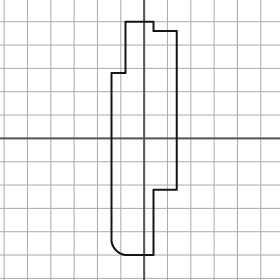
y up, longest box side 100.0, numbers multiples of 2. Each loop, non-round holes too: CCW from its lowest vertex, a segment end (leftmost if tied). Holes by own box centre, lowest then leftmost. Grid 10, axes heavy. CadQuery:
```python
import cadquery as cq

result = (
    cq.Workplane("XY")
    .moveTo(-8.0, -50.0)
    .lineTo(4.0, -50.0)
    .lineTo(4.0, -22.0)
    .lineTo(14.0, -22.0)
    .lineTo(14.0, 46.0)
    .lineTo(4.0, 46.0)
    .lineTo(4.0, 50.0)
    .lineTo(-8.0, 50.0)
    .lineTo(-8.0, 28.0)
    .lineTo(-14.0, 28.0)
    .lineTo(-14.0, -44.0)
    .threePointArc((-12.0, -48.0), (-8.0, -50.0))
    .close()
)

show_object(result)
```